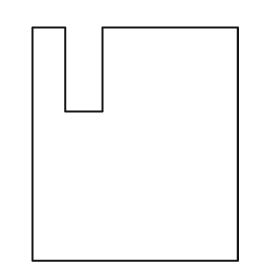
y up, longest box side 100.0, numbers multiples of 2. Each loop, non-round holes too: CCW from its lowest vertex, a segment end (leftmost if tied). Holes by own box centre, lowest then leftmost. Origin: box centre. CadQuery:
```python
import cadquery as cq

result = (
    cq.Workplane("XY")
    .moveTo(-44.0, -50.0)
    .lineTo(44.0, -50.0)
    .lineTo(44.0, 50.0)
    .lineTo(-14.0, 50.0)
    .lineTo(-14.0, 14.0)
    .lineTo(-30.0, 14.0)
    .lineTo(-30.0, 50.0)
    .lineTo(-44.0, 50.0)
    .close()
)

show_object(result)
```